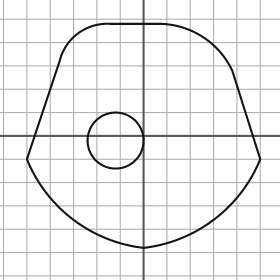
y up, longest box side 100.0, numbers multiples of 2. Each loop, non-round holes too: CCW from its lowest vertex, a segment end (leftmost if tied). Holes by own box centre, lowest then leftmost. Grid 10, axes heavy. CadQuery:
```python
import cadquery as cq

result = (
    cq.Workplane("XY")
    .moveTo(0.0, -48.0)
    .threePointArc((30.0, -36.0), (50.0, -10.0))
    .lineTo(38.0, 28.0)
    .threePointArc((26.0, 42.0), (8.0, 48.0))
    .lineTo(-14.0, 48.0)
    .threePointArc((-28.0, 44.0), (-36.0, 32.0))
    .lineTo(-50.0, -10.0)
    .threePointArc((-30.0, -36.0), (0.0, -48.0))
    .close()
    .moveTo(-12.0, -2.0)
    .circle(12.0)
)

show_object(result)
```